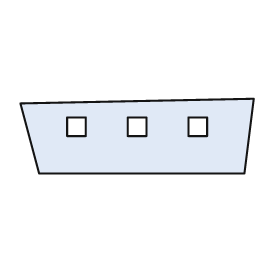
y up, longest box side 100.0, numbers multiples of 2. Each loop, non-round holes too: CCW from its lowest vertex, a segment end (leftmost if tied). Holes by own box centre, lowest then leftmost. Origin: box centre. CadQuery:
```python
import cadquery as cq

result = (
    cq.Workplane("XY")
    .moveTo(-42.0, -16.0)
    .lineTo(46.0, -16.0)
    .lineTo(50.0, 16.0)
    .lineTo(-50.0, 14.0)
    .close()
    .moveTo(-30.0, 0.0)
    .lineTo(-22.0, 0.0)
    .lineTo(-22.0, 8.0)
    .lineTo(-30.0, 8.0)
    .close()
    .moveTo(-4.0, 0.0)
    .lineTo(4.0, 0.0)
    .lineTo(4.0, 8.0)
    .lineTo(-4.0, 8.0)
    .close()
    .moveTo(22.0, 0.0)
    .lineTo(30.0, 0.0)
    .lineTo(30.0, 8.0)
    .lineTo(22.0, 8.0)
    .close()
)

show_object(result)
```